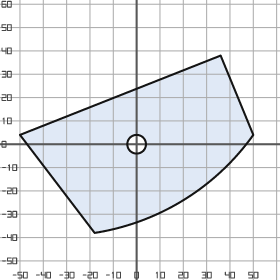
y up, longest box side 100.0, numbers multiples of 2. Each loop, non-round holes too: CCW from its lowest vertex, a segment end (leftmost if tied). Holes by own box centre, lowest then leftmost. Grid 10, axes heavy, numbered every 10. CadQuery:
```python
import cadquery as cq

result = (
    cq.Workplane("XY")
    .moveTo(-18.0, -38.0)
    .threePointArc((20.0, -24.0), (50.0, 4.0))
    .lineTo(36.0, 38.0)
    .lineTo(-50.0, 4.0)
    .close()
    .moveTo(0.0, 0.0)
    .circle(4.0)
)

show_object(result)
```